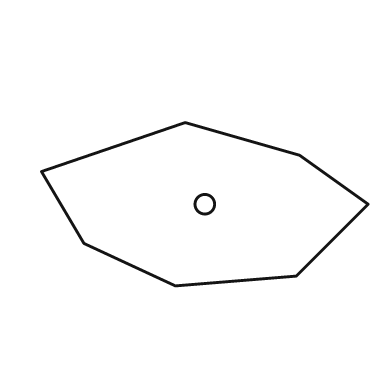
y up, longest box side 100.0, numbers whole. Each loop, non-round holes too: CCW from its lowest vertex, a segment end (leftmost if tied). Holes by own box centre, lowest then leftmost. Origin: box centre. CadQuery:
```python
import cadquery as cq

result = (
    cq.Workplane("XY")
    .moveTo(-9.0, -25.0)
    .lineTo(28.0, -22.0)
    .lineTo(50.0, 0.0)
    .lineTo(29.0, 15.0)
    .lineTo(-6.0, 25.0)
    .lineTo(-50.0, 10.0)
    .lineTo(-37.0, -12.0)
    .close()
    .moveTo(0.0, 0.0)
    .circle(3.0)
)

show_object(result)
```